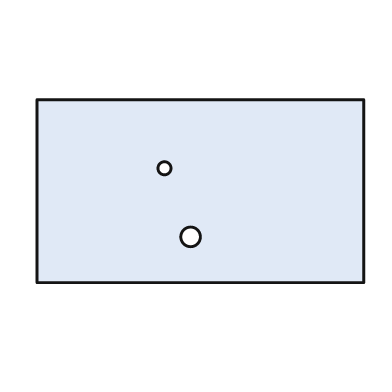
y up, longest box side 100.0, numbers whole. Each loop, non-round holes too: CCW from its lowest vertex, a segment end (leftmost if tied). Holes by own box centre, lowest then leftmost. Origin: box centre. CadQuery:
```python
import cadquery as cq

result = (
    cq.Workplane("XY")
    .moveTo(-50.0, -28.0)
    .lineTo(50.0, -28.0)
    .lineTo(50.0, 28.0)
    .lineTo(-50.0, 28.0)
    .close()
    .moveTo(-3.0, -14.0)
    .circle(3.0)
    .moveTo(-11.0, 7.0)
    .circle(2.0)
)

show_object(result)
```